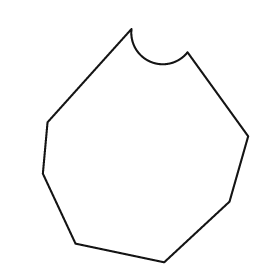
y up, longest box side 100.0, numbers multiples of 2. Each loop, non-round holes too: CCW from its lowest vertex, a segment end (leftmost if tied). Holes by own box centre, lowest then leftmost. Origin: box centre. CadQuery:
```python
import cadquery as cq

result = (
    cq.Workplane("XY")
    .moveTo(8.0, -50.0)
    .lineTo(36.0, -24.0)
    .lineTo(44.0, 4.0)
    .lineTo(18.0, 40.0)
    .threePointArc((2.0, 36.0), (-6.0, 50.0))
    .lineTo(-42.0, 10.0)
    .lineTo(-44.0, -12.0)
    .lineTo(-30.0, -42.0)
    .close()
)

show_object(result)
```